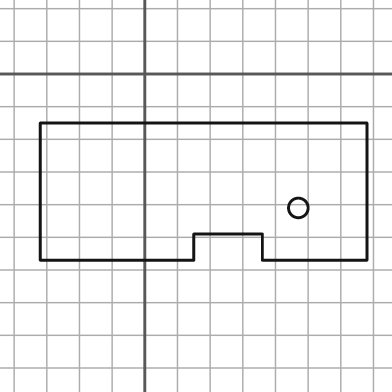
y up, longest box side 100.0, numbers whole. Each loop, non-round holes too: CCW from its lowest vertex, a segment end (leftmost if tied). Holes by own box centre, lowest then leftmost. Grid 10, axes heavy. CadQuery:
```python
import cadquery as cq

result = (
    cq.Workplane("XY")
    .moveTo(-32.0, -57.0)
    .lineTo(15.0, -57.0)
    .lineTo(15.0, -49.0)
    .lineTo(36.0, -49.0)
    .lineTo(36.0, -57.0)
    .lineTo(68.0, -57.0)
    .lineTo(68.0, -15.0)
    .lineTo(-32.0, -15.0)
    .close()
    .moveTo(47.0, -41.0)
    .circle(3.0)
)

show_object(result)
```